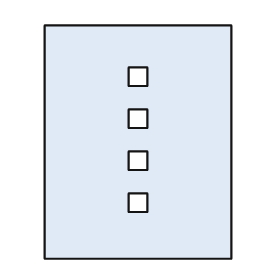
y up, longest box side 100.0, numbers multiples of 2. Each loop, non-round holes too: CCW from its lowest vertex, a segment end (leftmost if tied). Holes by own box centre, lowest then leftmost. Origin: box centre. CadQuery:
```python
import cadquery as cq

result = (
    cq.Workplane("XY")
    .moveTo(-40.0, -50.0)
    .lineTo(40.0, -50.0)
    .lineTo(40.0, 50.0)
    .lineTo(-40.0, 50.0)
    .close()
    .moveTo(-4.0, -30.0)
    .lineTo(4.0, -30.0)
    .lineTo(4.0, -22.0)
    .lineTo(-4.0, -22.0)
    .close()
    .moveTo(-4.0, -12.0)
    .lineTo(4.0, -12.0)
    .lineTo(4.0, -4.0)
    .lineTo(-4.0, -4.0)
    .close()
    .moveTo(-4.0, 6.0)
    .lineTo(4.0, 6.0)
    .lineTo(4.0, 14.0)
    .lineTo(-4.0, 14.0)
    .close()
    .moveTo(-4.0, 24.0)
    .lineTo(4.0, 24.0)
    .lineTo(4.0, 32.0)
    .lineTo(-4.0, 32.0)
    .close()
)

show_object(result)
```